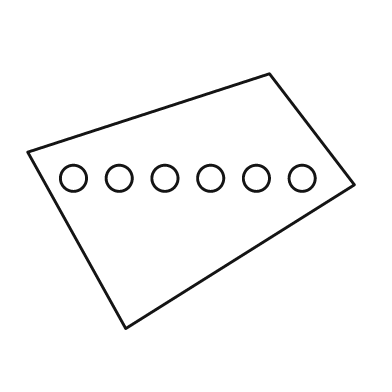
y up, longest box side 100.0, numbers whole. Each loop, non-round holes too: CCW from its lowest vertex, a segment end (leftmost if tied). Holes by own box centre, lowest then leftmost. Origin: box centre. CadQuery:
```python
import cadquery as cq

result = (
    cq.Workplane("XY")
    .moveTo(-20.0, -39.0)
    .lineTo(50.0, 5.0)
    .lineTo(24.0, 39.0)
    .lineTo(-50.0, 15.0)
    .close()
    .moveTo(-36.0, 7.0)
    .circle(4.0)
    .moveTo(-22.0, 7.0)
    .circle(4.0)
    .moveTo(-8.0, 7.0)
    .circle(4.0)
    .moveTo(6.0, 7.0)
    .circle(4.0)
    .moveTo(20.0, 7.0)
    .circle(4.0)
    .moveTo(34.0, 7.0)
    .circle(4.0)
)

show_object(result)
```